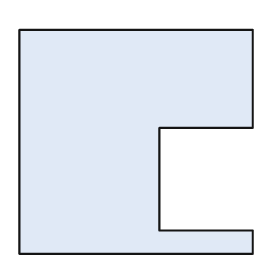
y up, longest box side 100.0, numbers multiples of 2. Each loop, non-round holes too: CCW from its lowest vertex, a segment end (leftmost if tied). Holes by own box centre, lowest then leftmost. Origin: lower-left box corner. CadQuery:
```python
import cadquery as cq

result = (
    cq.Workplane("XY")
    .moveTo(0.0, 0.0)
    .lineTo(100.0, 0.0)
    .lineTo(100.0, 10.0)
    .lineTo(60.0, 10.0)
    .lineTo(60.0, 54.0)
    .lineTo(100.0, 54.0)
    .lineTo(100.0, 96.0)
    .lineTo(0.0, 96.0)
    .close()
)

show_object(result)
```